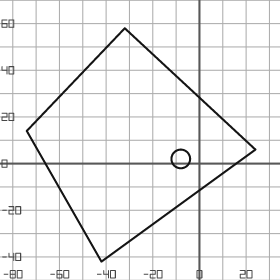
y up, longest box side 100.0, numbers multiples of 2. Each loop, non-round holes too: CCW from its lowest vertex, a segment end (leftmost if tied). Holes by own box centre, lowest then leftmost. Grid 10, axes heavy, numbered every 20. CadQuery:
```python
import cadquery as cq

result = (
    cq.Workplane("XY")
    .moveTo(-42.0, -42.0)
    .lineTo(24.0, 6.0)
    .lineTo(-32.0, 58.0)
    .lineTo(-74.0, 14.0)
    .close()
    .moveTo(-8.0, 2.0)
    .circle(4.0)
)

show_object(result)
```